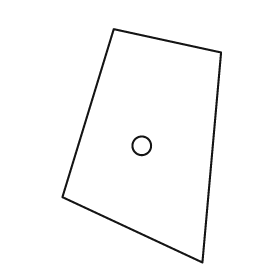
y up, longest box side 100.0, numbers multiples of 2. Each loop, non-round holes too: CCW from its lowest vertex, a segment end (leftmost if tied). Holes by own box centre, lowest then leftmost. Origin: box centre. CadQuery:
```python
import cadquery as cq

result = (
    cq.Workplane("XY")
    .moveTo(26.0, -50.0)
    .lineTo(34.0, 40.0)
    .lineTo(-12.0, 50.0)
    .lineTo(-34.0, -22.0)
    .close()
    .moveTo(0.0, 0.0)
    .circle(4.0)
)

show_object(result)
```